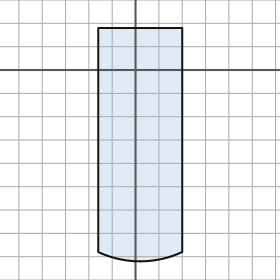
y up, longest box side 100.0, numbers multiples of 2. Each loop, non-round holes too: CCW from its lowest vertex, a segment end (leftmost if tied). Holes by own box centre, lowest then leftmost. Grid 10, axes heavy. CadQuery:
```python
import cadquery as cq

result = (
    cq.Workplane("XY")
    .moveTo(-16.0, -78.0)
    .threePointArc((2.0, -82.0), (20.0, -78.0))
    .lineTo(20.0, 18.0)
    .lineTo(-16.0, 18.0)
    .close()
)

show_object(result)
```